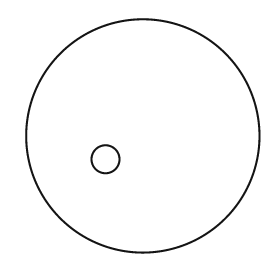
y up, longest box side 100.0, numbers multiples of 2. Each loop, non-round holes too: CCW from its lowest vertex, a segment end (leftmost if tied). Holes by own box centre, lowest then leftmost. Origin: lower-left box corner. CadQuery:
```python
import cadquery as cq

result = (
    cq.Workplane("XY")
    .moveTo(50.0, 50.0)
    .circle(50.0)
    .moveTo(34.0, 40.0)
    .circle(6.0)
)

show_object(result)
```